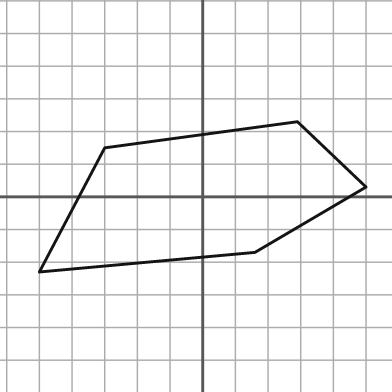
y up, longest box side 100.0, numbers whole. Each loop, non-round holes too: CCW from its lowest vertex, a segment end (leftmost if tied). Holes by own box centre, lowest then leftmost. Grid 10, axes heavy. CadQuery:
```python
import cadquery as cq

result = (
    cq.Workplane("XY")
    .moveTo(-50.0, -23.0)
    .lineTo(16.0, -17.0)
    .lineTo(50.0, 3.0)
    .lineTo(29.0, 23.0)
    .lineTo(-30.0, 15.0)
    .close()
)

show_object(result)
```